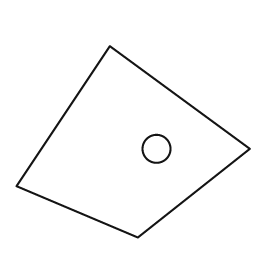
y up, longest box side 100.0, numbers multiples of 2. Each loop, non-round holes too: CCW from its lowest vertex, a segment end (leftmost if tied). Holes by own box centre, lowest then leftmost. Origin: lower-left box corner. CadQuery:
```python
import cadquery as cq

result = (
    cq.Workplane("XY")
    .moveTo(52.0, 0.0)
    .lineTo(100.0, 38.0)
    .lineTo(40.0, 82.0)
    .lineTo(0.0, 22.0)
    .close()
    .moveTo(60.0, 38.0)
    .circle(6.0)
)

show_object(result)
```